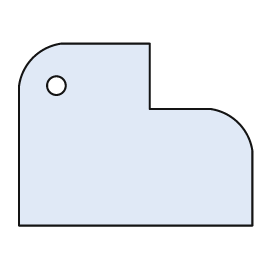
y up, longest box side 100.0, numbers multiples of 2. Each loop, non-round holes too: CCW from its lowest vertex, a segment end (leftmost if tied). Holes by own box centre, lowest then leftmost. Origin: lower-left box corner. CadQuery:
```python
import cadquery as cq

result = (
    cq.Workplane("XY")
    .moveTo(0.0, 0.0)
    .lineTo(100.0, 0.0)
    .lineTo(100.0, 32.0)
    .threePointArc((94.0, 44.0), (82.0, 50.0))
    .lineTo(56.0, 50.0)
    .lineTo(56.0, 78.0)
    .lineTo(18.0, 78.0)
    .threePointArc((6.0, 72.0), (0.0, 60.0))
    .close()
    .moveTo(16.0, 60.0)
    .circle(4.0)
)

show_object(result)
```